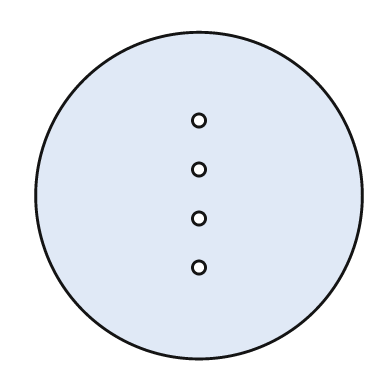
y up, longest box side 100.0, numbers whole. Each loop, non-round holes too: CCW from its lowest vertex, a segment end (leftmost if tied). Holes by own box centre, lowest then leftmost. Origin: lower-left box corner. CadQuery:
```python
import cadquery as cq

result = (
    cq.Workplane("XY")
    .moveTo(50.0, 50.0)
    .circle(50.0)
    .moveTo(50.0, 28.0)
    .circle(2.0)
    .moveTo(50.0, 43.0)
    .circle(2.0)
    .moveTo(50.0, 58.0)
    .circle(2.0)
    .moveTo(50.0, 73.0)
    .circle(2.0)
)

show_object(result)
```